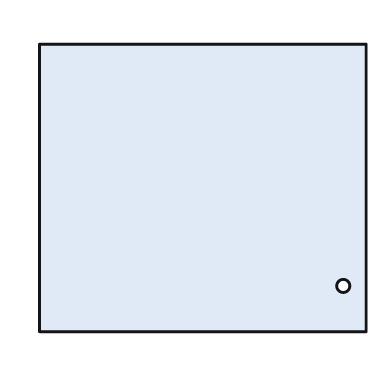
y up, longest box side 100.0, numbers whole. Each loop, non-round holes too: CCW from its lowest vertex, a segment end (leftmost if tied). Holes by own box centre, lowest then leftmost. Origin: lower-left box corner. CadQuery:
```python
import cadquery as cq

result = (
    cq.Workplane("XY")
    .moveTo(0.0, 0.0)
    .lineTo(100.0, 0.0)
    .lineTo(100.0, 88.0)
    .lineTo(0.0, 88.0)
    .close()
    .moveTo(93.0, 14.0)
    .circle(2.0)
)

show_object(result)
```